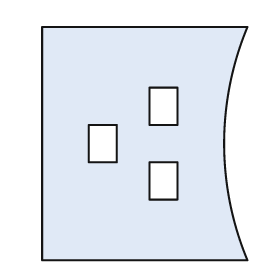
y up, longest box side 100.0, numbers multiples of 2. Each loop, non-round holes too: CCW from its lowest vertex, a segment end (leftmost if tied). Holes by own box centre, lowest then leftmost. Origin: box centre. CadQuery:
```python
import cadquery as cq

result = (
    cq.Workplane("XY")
    .moveTo(-44.0, -50.0)
    .lineTo(44.0, -50.0)
    .threePointArc((34.0, 0.0), (44.0, 50.0))
    .lineTo(-44.0, 50.0)
    .close()
    .moveTo(2.0, -24.0)
    .lineTo(14.0, -24.0)
    .lineTo(14.0, -8.0)
    .lineTo(2.0, -8.0)
    .close()
    .moveTo(-24.0, -8.0)
    .lineTo(-12.0, -8.0)
    .lineTo(-12.0, 8.0)
    .lineTo(-24.0, 8.0)
    .close()
    .moveTo(2.0, 8.0)
    .lineTo(14.0, 8.0)
    .lineTo(14.0, 24.0)
    .lineTo(2.0, 24.0)
    .close()
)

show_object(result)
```